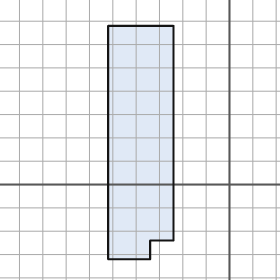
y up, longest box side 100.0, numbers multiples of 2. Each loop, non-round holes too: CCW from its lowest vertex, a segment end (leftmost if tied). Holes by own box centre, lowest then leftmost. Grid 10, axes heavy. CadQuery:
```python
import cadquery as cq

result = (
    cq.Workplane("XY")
    .moveTo(-52.0, -32.0)
    .lineTo(-34.0, -32.0)
    .lineTo(-34.0, -24.0)
    .lineTo(-24.0, -24.0)
    .lineTo(-24.0, 68.0)
    .lineTo(-52.0, 68.0)
    .close()
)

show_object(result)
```